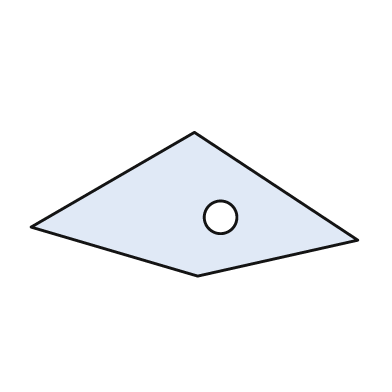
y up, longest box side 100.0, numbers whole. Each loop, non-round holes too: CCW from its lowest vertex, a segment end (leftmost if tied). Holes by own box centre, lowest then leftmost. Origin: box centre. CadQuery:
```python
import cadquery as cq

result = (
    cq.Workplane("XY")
    .moveTo(1.0, -22.0)
    .lineTo(50.0, -11.0)
    .lineTo(0.0, 22.0)
    .lineTo(-50.0, -7.0)
    .close()
    .moveTo(8.0, -4.0)
    .circle(5.0)
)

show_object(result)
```